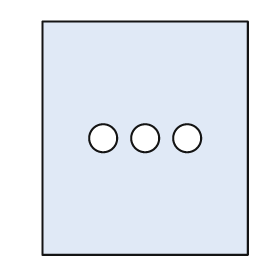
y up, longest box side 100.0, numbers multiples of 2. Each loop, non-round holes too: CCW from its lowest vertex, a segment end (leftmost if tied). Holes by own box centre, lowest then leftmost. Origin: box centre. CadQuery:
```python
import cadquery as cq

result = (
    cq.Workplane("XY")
    .moveTo(-44.0, -50.0)
    .lineTo(44.0, -50.0)
    .lineTo(44.0, 50.0)
    .lineTo(-44.0, 50.0)
    .close()
    .moveTo(-18.0, 0.0)
    .circle(6.0)
    .moveTo(0.0, 0.0)
    .circle(6.0)
    .moveTo(18.0, 0.0)
    .circle(6.0)
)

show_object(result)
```